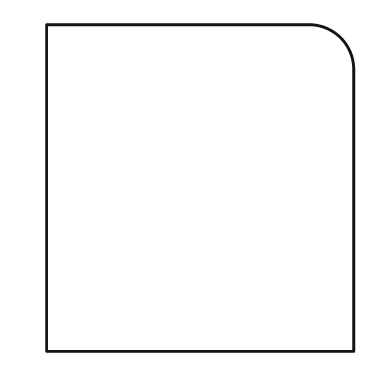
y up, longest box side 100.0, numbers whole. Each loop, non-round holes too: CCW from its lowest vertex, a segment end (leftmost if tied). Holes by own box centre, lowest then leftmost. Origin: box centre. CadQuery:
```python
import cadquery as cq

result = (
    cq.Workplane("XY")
    .moveTo(-47.0, -50.0)
    .lineTo(47.0, -50.0)
    .lineTo(47.0, 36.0)
    .threePointArc((43.0, 46.0), (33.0, 50.0))
    .lineTo(-47.0, 50.0)
    .close()
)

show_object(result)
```